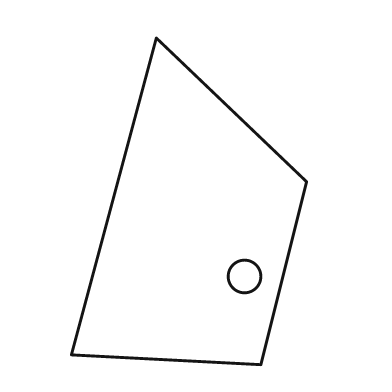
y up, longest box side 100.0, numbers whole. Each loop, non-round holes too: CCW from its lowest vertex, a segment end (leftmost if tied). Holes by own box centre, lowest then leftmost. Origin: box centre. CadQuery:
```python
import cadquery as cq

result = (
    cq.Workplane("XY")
    .moveTo(22.0, -50.0)
    .lineTo(36.0, 6.0)
    .lineTo(-10.0, 50.0)
    .lineTo(-36.0, -47.0)
    .close()
    .moveTo(17.0, -23.0)
    .circle(5.0)
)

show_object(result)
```